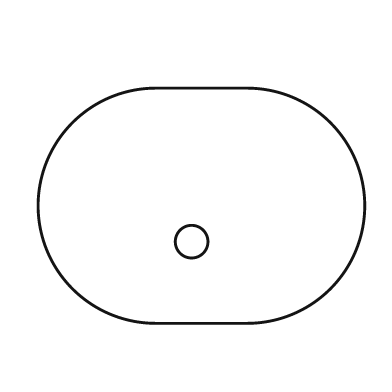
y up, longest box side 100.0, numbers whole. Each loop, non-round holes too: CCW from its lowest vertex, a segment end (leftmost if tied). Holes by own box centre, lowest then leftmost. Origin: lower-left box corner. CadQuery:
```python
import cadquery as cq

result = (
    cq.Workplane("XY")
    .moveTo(36.0, 0.0)
    .lineTo(64.0, 0.0)
    .threePointArc((100.0, 36.0), (64.0, 72.0))
    .lineTo(36.0, 72.0)
    .threePointArc((0.0, 36.0), (36.0, 0.0))
    .close()
    .moveTo(47.0, 25.0)
    .circle(5.0)
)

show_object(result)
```